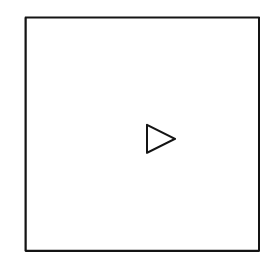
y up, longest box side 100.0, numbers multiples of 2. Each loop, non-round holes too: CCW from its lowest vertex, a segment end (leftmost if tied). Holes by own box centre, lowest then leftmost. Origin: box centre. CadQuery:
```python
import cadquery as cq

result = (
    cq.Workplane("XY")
    .moveTo(-50.0, -50.0)
    .lineTo(50.0, -50.0)
    .lineTo(50.0, 50.0)
    .lineTo(-50.0, 50.0)
    .close()
    .moveTo(2.0, -8.0)
    .lineTo(14.0, -2.0)
    .lineTo(2.0, 4.0)
    .close()
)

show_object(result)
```